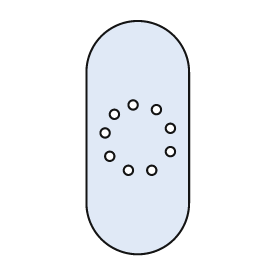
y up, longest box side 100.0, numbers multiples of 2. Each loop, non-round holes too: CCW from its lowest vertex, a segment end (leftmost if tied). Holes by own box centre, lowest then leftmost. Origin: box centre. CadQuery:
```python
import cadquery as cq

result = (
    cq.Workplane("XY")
    .moveTo(-22.0, -28.0)
    .threePointArc((0.0, -50.0), (22.0, -28.0))
    .lineTo(22.0, 28.0)
    .threePointArc((0.0, 50.0), (-22.0, 28.0))
    .close()
    .moveTo(-4.0, -14.0)
    .circle(2.0)
    .moveTo(6.0, -14.0)
    .circle(2.0)
    .moveTo(-12.0, -8.0)
    .circle(2.0)
    .moveTo(14.0, -6.0)
    .circle(2.0)
    .moveTo(-14.0, 2.0)
    .circle(2.0)
    .moveTo(14.0, 4.0)
    .circle(2.0)
    .moveTo(-10.0, 10.0)
    .circle(2.0)
    .moveTo(8.0, 12.0)
    .circle(2.0)
    .moveTo(-2.0, 14.0)
    .circle(2.0)
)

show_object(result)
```